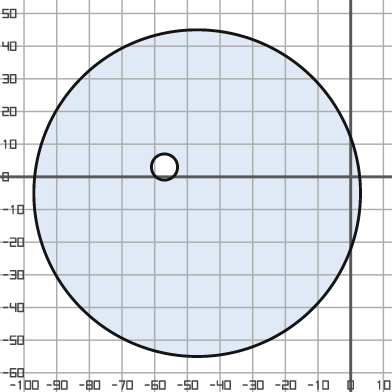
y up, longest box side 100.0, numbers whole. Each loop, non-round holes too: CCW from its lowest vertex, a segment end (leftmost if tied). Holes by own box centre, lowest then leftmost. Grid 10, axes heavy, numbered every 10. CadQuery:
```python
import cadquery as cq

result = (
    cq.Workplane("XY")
    .moveTo(-47.0, -5.0)
    .circle(50.0)
    .moveTo(-57.0, 3.0)
    .circle(4.0)
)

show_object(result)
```